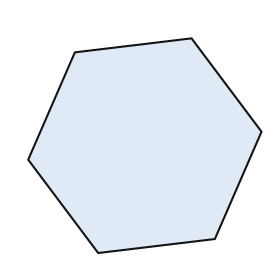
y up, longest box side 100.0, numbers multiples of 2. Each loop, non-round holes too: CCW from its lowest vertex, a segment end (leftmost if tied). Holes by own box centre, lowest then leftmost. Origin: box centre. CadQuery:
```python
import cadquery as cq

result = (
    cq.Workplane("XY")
    .moveTo(-20.0, -46.0)
    .lineTo(30.0, -40.0)
    .lineTo(50.0, 6.0)
    .lineTo(20.0, 46.0)
    .lineTo(-30.0, 40.0)
    .lineTo(-50.0, -6.0)
    .close()
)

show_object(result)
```